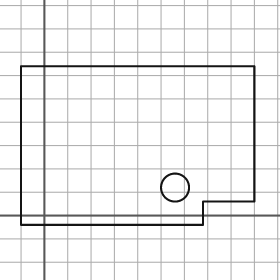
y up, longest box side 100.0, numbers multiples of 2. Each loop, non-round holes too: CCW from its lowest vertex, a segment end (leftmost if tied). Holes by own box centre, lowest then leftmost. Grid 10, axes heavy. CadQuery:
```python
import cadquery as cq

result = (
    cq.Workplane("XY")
    .moveTo(-10.0, -4.0)
    .lineTo(68.0, -4.0)
    .lineTo(68.0, 6.0)
    .lineTo(90.0, 6.0)
    .lineTo(90.0, 64.0)
    .lineTo(-10.0, 64.0)
    .close()
    .moveTo(56.0, 12.0)
    .circle(6.0)
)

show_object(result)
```